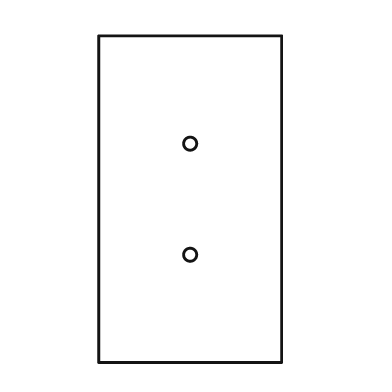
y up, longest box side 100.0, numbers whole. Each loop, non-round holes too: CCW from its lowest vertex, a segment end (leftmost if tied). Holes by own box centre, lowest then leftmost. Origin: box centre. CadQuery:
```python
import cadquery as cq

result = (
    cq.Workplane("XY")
    .moveTo(-28.0, -50.0)
    .lineTo(28.0, -50.0)
    .lineTo(28.0, 50.0)
    .lineTo(-28.0, 50.0)
    .close()
    .moveTo(0.0, -17.0)
    .circle(2.0)
    .moveTo(0.0, 17.0)
    .circle(2.0)
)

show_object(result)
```